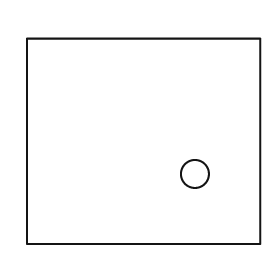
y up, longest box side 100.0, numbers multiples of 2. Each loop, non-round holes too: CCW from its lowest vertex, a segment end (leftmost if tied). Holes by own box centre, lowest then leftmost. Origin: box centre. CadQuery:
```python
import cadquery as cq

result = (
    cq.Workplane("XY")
    .moveTo(-50.0, -44.0)
    .lineTo(50.0, -44.0)
    .lineTo(50.0, 44.0)
    .lineTo(-50.0, 44.0)
    .close()
    .moveTo(22.0, -14.0)
    .circle(6.0)
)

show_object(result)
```